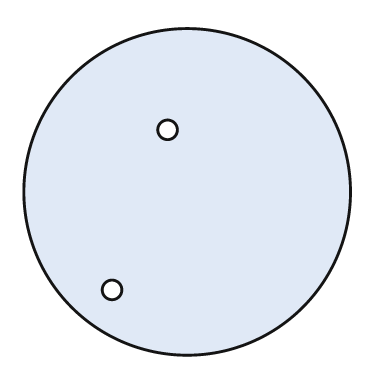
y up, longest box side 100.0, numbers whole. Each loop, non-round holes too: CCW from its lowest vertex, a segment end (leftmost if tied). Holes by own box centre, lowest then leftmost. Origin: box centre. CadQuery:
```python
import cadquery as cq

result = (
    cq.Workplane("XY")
    .moveTo(0.0, 0.0)
    .circle(50.0)
    .moveTo(-23.0, -30.0)
    .circle(3.0)
    .moveTo(-6.0, 19.0)
    .circle(3.0)
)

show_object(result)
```